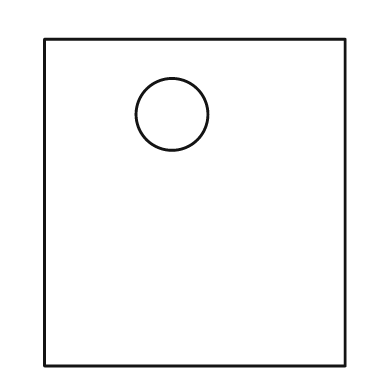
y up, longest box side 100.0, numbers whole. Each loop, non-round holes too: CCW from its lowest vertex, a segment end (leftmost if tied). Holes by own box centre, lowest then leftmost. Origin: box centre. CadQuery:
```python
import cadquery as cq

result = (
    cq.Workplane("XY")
    .moveTo(-46.0, -50.0)
    .lineTo(46.0, -50.0)
    .lineTo(46.0, 50.0)
    .lineTo(-46.0, 50.0)
    .close()
    .moveTo(-7.0, 27.0)
    .circle(11.0)
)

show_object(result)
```